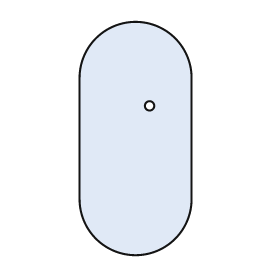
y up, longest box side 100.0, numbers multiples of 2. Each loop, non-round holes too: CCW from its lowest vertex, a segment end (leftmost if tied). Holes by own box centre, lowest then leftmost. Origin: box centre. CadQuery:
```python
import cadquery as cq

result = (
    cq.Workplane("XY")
    .moveTo(-24.0, -26.0)
    .threePointArc((0.0, -50.0), (24.0, -26.0))
    .lineTo(24.0, 26.0)
    .threePointArc((0.0, 50.0), (-24.0, 26.0))
    .close()
    .moveTo(6.0, 14.0)
    .circle(2.0)
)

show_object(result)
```